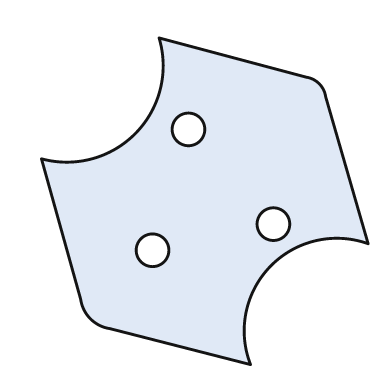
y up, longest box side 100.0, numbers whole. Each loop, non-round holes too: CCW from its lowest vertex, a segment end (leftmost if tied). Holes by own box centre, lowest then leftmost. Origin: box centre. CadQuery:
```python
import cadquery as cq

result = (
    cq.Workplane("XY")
    .moveTo(14.0, -50.0)
    .threePointArc((20.0, -20.0), (50.0, -13.0))
    .lineTo(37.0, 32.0)
    .threePointArc((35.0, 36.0), (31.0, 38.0))
    .lineTo(-14.0, 50.0)
    .threePointArc((-21.0, 21.0), (-50.0, 13.0))
    .lineTo(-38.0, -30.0)
    .threePointArc((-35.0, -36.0), (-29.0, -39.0))
    .close()
    .moveTo(-16.0, -15.0)
    .circle(5.0)
    .moveTo(21.0, -7.0)
    .circle(5.0)
    .moveTo(-5.0, 22.0)
    .circle(5.0)
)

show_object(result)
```